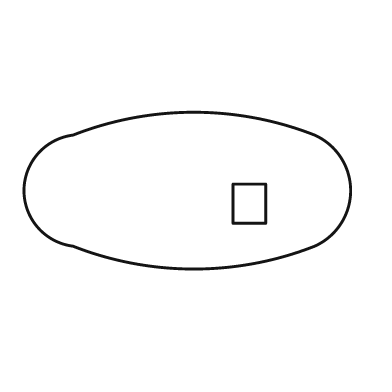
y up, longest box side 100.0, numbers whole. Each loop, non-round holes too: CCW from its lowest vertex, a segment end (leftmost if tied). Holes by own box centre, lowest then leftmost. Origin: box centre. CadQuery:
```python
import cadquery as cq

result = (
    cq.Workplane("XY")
    .moveTo(-35.0, -17.0)
    .threePointArc((2.0, -24.0), (39.0, -17.0))
    .threePointArc((50.0, 0.0), (39.0, 17.0))
    .threePointArc((2.0, 24.0), (-35.0, 17.0))
    .threePointArc((-50.0, 0.0), (-35.0, -17.0))
    .close()
    .moveTo(14.0, -10.0)
    .lineTo(24.0, -10.0)
    .lineTo(24.0, 2.0)
    .lineTo(14.0, 2.0)
    .close()
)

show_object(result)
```